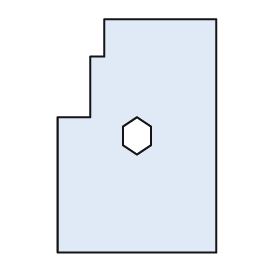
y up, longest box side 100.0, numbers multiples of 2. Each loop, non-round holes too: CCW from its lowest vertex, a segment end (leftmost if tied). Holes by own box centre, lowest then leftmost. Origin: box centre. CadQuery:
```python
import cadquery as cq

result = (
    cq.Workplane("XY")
    .moveTo(-34.0, -50.0)
    .lineTo(34.0, -50.0)
    .lineTo(34.0, 50.0)
    .lineTo(-14.0, 50.0)
    .lineTo(-14.0, 34.0)
    .lineTo(-20.0, 34.0)
    .lineTo(-20.0, 8.0)
    .lineTo(-34.0, 8.0)
    .close()
    .moveTo(0.0, -8.0)
    .lineTo(6.0, -4.0)
    .lineTo(6.0, 4.0)
    .lineTo(0.0, 8.0)
    .lineTo(-6.0, 4.0)
    .lineTo(-6.0, -4.0)
    .close()
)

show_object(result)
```